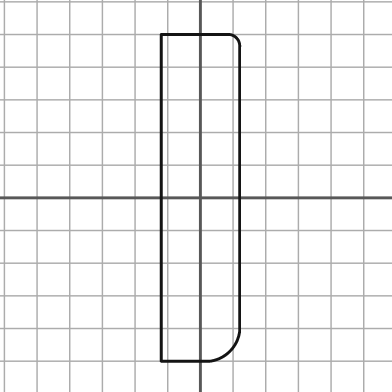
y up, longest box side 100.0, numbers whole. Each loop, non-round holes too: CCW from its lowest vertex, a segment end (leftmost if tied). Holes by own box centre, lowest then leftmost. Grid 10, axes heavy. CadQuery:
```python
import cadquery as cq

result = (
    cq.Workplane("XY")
    .moveTo(-12.0, -50.0)
    .lineTo(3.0, -50.0)
    .threePointArc((9.0, -47.0), (12.0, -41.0))
    .lineTo(12.0, 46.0)
    .threePointArc((11.0, 49.0), (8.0, 50.0))
    .lineTo(-12.0, 50.0)
    .close()
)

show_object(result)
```